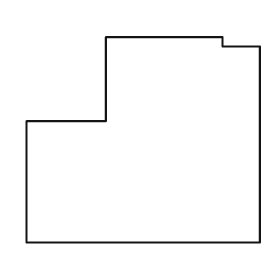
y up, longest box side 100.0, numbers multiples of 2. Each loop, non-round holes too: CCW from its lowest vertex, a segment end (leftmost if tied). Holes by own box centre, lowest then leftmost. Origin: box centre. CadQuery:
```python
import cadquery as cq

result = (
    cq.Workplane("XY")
    .moveTo(-50.0, -44.0)
    .lineTo(50.0, -44.0)
    .lineTo(50.0, 40.0)
    .lineTo(34.0, 40.0)
    .lineTo(34.0, 44.0)
    .lineTo(-16.0, 44.0)
    .lineTo(-16.0, 8.0)
    .lineTo(-50.0, 8.0)
    .close()
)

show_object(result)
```